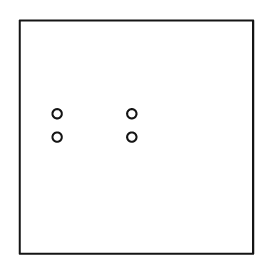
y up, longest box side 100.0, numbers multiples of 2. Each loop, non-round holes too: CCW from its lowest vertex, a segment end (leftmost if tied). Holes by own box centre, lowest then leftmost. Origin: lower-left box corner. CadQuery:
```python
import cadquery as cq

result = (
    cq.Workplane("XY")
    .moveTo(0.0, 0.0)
    .lineTo(100.0, 0.0)
    .lineTo(100.0, 100.0)
    .lineTo(0.0, 100.0)
    .close()
    .moveTo(16.0, 50.0)
    .circle(2.0)
    .moveTo(48.0, 50.0)
    .circle(2.0)
    .moveTo(16.0, 60.0)
    .circle(2.0)
    .moveTo(48.0, 60.0)
    .circle(2.0)
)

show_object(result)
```